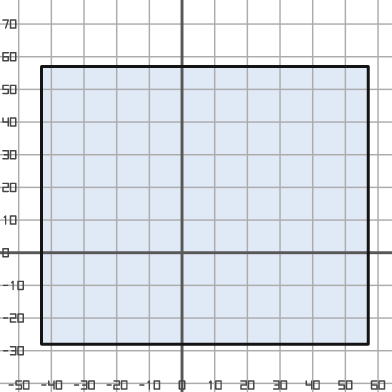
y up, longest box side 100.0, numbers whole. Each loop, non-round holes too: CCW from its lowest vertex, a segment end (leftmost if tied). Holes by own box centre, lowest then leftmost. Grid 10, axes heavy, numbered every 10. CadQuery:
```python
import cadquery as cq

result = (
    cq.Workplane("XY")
    .moveTo(-43.0, -28.0)
    .lineTo(57.0, -28.0)
    .lineTo(57.0, 57.0)
    .lineTo(-43.0, 57.0)
    .close()
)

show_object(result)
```